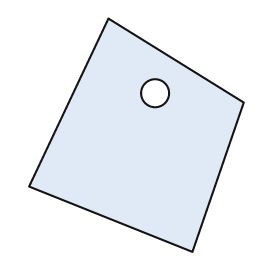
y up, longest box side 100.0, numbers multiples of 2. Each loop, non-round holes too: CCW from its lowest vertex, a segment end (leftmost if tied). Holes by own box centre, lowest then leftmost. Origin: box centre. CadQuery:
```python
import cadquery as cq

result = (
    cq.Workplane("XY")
    .moveTo(24.0, -50.0)
    .lineTo(46.0, 14.0)
    .lineTo(-12.0, 50.0)
    .lineTo(-46.0, -22.0)
    .close()
    .moveTo(8.0, 18.0)
    .circle(6.0)
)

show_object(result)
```